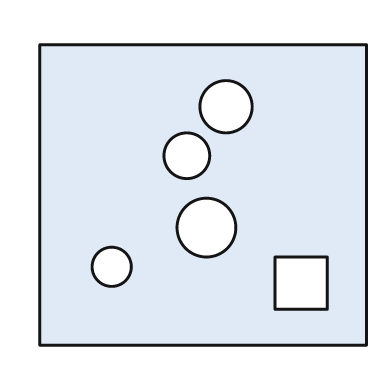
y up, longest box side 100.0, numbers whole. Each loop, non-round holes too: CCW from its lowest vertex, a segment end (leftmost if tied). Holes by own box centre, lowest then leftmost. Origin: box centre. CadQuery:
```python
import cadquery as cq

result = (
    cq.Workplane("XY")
    .moveTo(-50.0, -46.0)
    .lineTo(50.0, -46.0)
    .lineTo(50.0, 46.0)
    .lineTo(-50.0, 46.0)
    .close()
    .moveTo(22.0, -35.0)
    .lineTo(38.0, -35.0)
    .lineTo(38.0, -19.0)
    .lineTo(22.0, -19.0)
    .close()
    .moveTo(-28.0, -22.0)
    .circle(6.0)
    .moveTo(1.0, -10.0)
    .circle(9.0)
    .moveTo(-5.0, 12.0)
    .circle(7.0)
    .moveTo(7.0, 27.0)
    .circle(8.0)
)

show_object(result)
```